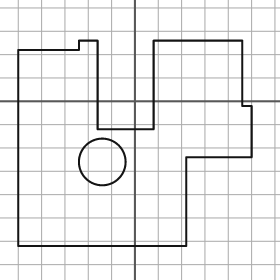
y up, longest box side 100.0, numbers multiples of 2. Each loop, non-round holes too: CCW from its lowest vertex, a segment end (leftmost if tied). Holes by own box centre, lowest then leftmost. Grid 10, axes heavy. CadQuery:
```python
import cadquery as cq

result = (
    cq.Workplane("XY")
    .moveTo(-50.0, -62.0)
    .lineTo(22.0, -62.0)
    .lineTo(22.0, -24.0)
    .lineTo(50.0, -24.0)
    .lineTo(50.0, -2.0)
    .lineTo(46.0, -2.0)
    .lineTo(46.0, 26.0)
    .lineTo(8.0, 26.0)
    .lineTo(8.0, -12.0)
    .lineTo(-16.0, -12.0)
    .lineTo(-16.0, 26.0)
    .lineTo(-24.0, 26.0)
    .lineTo(-24.0, 22.0)
    .lineTo(-50.0, 22.0)
    .close()
    .moveTo(-14.0, -26.0)
    .circle(10.0)
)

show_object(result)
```